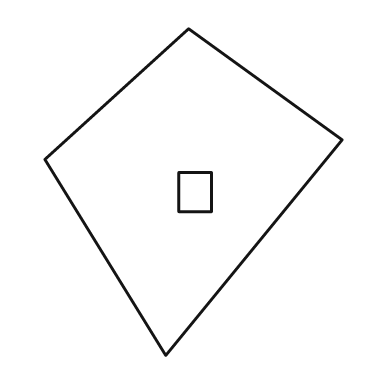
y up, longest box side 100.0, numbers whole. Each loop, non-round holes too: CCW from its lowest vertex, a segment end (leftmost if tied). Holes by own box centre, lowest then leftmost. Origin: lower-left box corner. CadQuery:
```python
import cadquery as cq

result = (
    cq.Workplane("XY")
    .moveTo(37.0, 0.0)
    .lineTo(91.0, 66.0)
    .lineTo(44.0, 100.0)
    .lineTo(0.0, 60.0)
    .close()
    .moveTo(41.0, 44.0)
    .lineTo(51.0, 44.0)
    .lineTo(51.0, 56.0)
    .lineTo(41.0, 56.0)
    .close()
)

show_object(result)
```